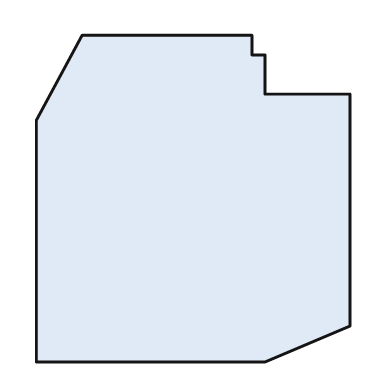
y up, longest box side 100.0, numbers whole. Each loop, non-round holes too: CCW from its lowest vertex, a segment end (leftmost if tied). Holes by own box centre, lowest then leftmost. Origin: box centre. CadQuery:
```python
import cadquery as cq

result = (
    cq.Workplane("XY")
    .moveTo(-48.0, -50.0)
    .lineTo(22.0, -50.0)
    .lineTo(48.0, -39.0)
    .lineTo(48.0, 32.0)
    .lineTo(22.0, 32.0)
    .lineTo(22.0, 44.0)
    .lineTo(18.0, 44.0)
    .lineTo(18.0, 50.0)
    .lineTo(-34.0, 50.0)
    .lineTo(-48.0, 24.0)
    .close()
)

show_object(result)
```